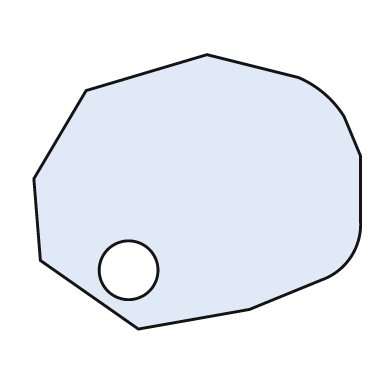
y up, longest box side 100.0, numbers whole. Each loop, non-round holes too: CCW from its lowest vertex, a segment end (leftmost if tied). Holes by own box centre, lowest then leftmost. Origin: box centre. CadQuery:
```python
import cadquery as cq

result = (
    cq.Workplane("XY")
    .moveTo(-18.0, -42.0)
    .lineTo(16.0, -36.0)
    .lineTo(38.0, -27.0)
    .threePointArc((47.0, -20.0), (50.0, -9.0))
    .lineTo(50.0, 11.0)
    .lineTo(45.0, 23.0)
    .threePointArc((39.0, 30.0), (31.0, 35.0))
    .lineTo(3.0, 42.0)
    .lineTo(-34.0, 31.0)
    .lineTo(-50.0, 4.0)
    .lineTo(-48.0, -21.0)
    .close()
    .moveTo(-21.0, -24.0)
    .circle(9.0)
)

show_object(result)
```